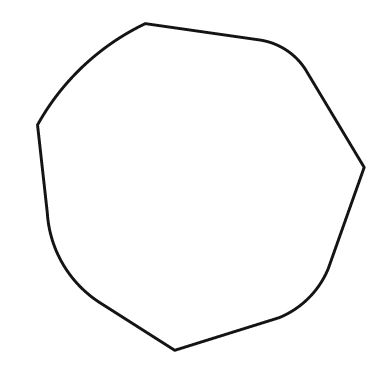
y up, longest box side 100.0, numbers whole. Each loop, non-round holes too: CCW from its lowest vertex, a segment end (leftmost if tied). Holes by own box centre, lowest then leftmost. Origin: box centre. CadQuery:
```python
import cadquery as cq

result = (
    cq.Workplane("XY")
    .moveTo(-8.0, -50.0)
    .lineTo(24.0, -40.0)
    .threePointArc((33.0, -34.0), (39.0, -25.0))
    .lineTo(50.0, 6.0)
    .lineTo(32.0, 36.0)
    .threePointArc((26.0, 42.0), (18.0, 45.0))
    .lineTo(-17.0, 50.0)
    .threePointArc((-36.0, 37.0), (-50.0, 19.0))
    .lineTo(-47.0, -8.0)
    .threePointArc((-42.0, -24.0), (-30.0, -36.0))
    .close()
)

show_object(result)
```